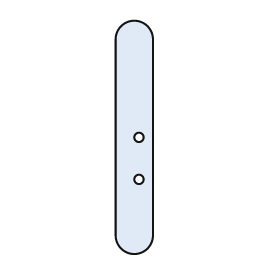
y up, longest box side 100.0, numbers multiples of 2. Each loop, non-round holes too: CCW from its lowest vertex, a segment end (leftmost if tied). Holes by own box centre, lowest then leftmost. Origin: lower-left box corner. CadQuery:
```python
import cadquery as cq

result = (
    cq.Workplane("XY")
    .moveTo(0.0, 8.0)
    .threePointArc((8.0, 0.0), (16.0, 8.0))
    .lineTo(16.0, 92.0)
    .threePointArc((8.0, 100.0), (0.0, 92.0))
    .close()
    .moveTo(10.0, 32.0)
    .circle(2.0)
    .moveTo(10.0, 50.0)
    .circle(2.0)
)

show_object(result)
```